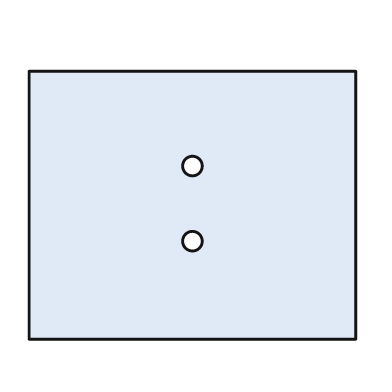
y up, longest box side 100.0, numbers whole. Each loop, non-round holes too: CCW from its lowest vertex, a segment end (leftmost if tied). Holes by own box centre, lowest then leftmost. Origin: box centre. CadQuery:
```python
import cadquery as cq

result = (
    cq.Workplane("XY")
    .moveTo(-50.0, -41.0)
    .lineTo(50.0, -41.0)
    .lineTo(50.0, 41.0)
    .lineTo(-50.0, 41.0)
    .close()
    .moveTo(0.0, -11.0)
    .circle(3.0)
    .moveTo(0.0, 12.0)
    .circle(3.0)
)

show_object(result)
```